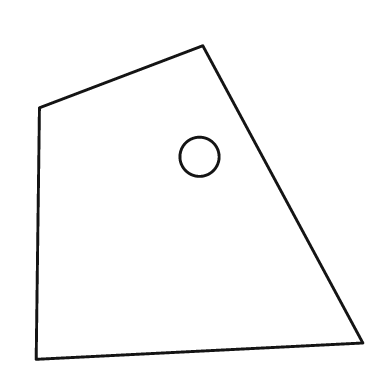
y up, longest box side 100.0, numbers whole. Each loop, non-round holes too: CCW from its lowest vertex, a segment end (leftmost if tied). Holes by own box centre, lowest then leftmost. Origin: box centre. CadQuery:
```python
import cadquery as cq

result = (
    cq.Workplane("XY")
    .moveTo(-50.0, -48.0)
    .lineTo(50.0, -43.0)
    .lineTo(1.0, 48.0)
    .lineTo(-49.0, 29.0)
    .close()
    .moveTo(0.0, 14.0)
    .circle(6.0)
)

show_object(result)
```